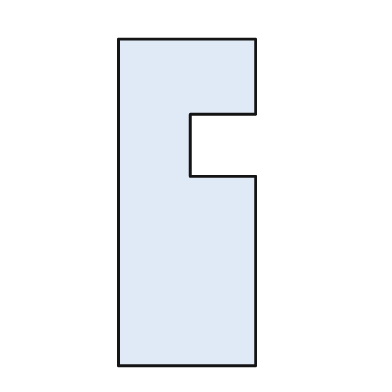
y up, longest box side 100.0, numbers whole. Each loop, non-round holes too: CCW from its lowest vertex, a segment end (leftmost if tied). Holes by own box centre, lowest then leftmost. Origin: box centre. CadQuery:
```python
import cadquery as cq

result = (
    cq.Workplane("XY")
    .moveTo(-21.0, -50.0)
    .lineTo(21.0, -50.0)
    .lineTo(21.0, 8.0)
    .lineTo(1.0, 8.0)
    .lineTo(1.0, 27.0)
    .lineTo(21.0, 27.0)
    .lineTo(21.0, 50.0)
    .lineTo(-21.0, 50.0)
    .close()
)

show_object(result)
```